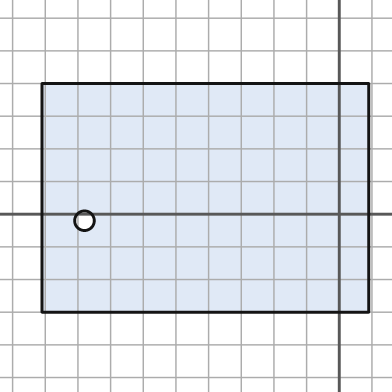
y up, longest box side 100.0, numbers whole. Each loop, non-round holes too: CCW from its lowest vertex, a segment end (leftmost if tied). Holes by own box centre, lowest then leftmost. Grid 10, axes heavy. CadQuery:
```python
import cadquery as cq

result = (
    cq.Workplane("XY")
    .moveTo(-91.0, -30.0)
    .lineTo(9.0, -30.0)
    .lineTo(9.0, 40.0)
    .lineTo(-91.0, 40.0)
    .close()
    .moveTo(-78.0, -2.0)
    .circle(3.0)
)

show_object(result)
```